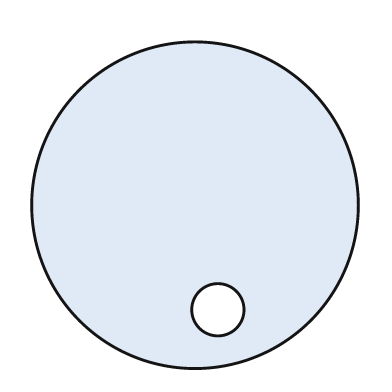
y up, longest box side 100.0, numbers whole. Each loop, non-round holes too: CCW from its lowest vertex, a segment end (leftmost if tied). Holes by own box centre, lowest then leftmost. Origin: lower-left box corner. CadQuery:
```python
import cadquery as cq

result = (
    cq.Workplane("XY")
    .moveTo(50.0, 50.0)
    .circle(50.0)
    .moveTo(57.0, 18.0)
    .circle(8.0)
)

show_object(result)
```